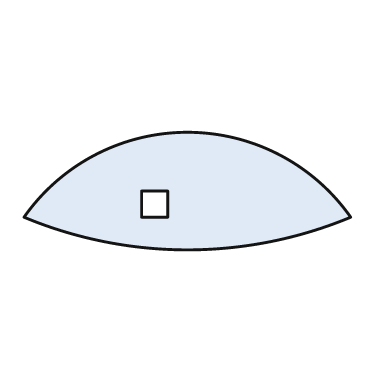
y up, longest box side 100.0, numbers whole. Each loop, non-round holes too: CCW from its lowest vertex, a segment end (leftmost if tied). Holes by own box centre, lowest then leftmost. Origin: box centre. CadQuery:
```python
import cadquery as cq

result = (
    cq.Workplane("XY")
    .moveTo(-50.0, -8.0)
    .threePointArc((0.0, -18.0), (50.0, -8.0))
    .threePointArc((0.0, 18.0), (-50.0, -8.0))
    .close()
    .moveTo(-14.0, -8.0)
    .lineTo(-6.0, -8.0)
    .lineTo(-6.0, 0.0)
    .lineTo(-14.0, 0.0)
    .close()
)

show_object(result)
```